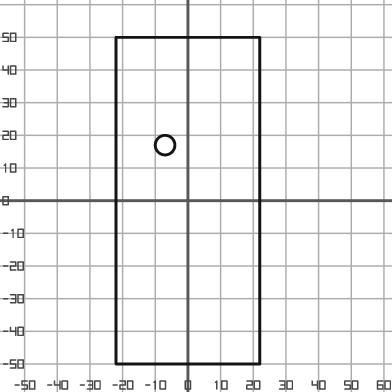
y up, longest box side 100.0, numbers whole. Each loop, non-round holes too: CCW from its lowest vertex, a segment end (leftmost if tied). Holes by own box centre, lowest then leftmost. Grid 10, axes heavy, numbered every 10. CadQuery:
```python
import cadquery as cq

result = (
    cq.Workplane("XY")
    .moveTo(-22.0, -50.0)
    .lineTo(22.0, -50.0)
    .lineTo(22.0, 50.0)
    .lineTo(-22.0, 50.0)
    .close()
    .moveTo(-7.0, 17.0)
    .circle(3.0)
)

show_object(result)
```